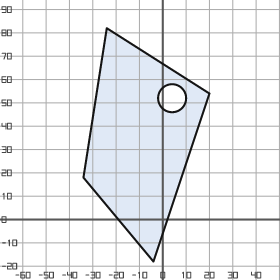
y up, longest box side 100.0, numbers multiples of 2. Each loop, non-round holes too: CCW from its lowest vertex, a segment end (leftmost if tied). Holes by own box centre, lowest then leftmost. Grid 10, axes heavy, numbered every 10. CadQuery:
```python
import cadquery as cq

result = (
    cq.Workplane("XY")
    .moveTo(-4.0, -18.0)
    .lineTo(20.0, 54.0)
    .lineTo(-24.0, 82.0)
    .lineTo(-34.0, 18.0)
    .close()
    .moveTo(4.0, 52.0)
    .circle(6.0)
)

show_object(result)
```